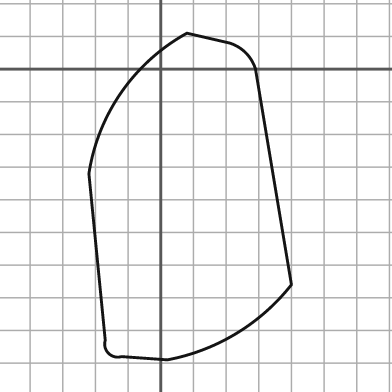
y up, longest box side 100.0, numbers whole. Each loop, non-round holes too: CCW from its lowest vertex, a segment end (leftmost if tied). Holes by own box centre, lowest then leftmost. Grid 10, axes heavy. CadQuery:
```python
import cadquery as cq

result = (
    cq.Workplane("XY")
    .moveTo(2.0, -89.0)
    .threePointArc((23.0, -81.0), (40.0, -66.0))
    .lineTo(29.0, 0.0)
    .threePointArc((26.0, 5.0), (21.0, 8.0))
    .lineTo(8.0, 11.0)
    .threePointArc((-12.0, -7.0), (-22.0, -32.0))
    .lineTo(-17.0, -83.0)
    .threePointArc((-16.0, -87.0), (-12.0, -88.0))
    .close()
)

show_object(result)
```